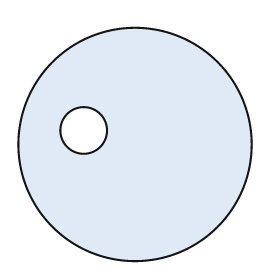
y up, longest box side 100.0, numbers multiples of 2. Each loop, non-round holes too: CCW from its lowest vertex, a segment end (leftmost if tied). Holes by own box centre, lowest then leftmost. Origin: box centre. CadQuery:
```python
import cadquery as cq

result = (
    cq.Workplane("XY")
    .moveTo(0.0, 0.0)
    .circle(50.0)
    .moveTo(-22.0, 6.0)
    .circle(10.0)
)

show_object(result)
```